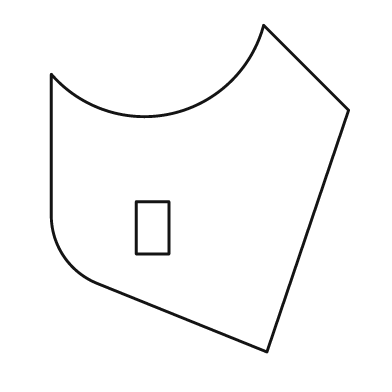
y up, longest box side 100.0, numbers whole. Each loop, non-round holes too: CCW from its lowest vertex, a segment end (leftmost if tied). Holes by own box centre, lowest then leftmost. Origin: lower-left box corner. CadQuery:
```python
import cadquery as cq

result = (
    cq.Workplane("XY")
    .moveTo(66.0, 0.0)
    .lineTo(91.0, 74.0)
    .lineTo(65.0, 100.0)
    .threePointArc((37.0, 73.0), (0.0, 85.0))
    .lineTo(0.0, 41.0)
    .threePointArc((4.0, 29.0), (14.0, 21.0))
    .close()
    .moveTo(26.0, 30.0)
    .lineTo(36.0, 30.0)
    .lineTo(36.0, 46.0)
    .lineTo(26.0, 46.0)
    .close()
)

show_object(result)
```